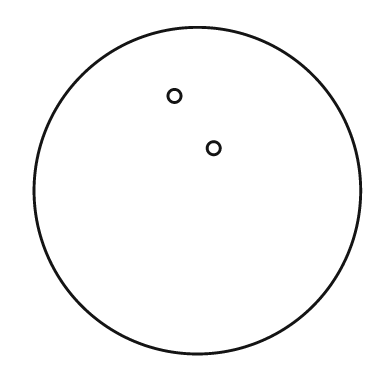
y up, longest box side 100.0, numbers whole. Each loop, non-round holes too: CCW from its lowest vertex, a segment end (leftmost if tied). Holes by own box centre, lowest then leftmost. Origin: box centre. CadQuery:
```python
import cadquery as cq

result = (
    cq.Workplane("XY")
    .moveTo(0.0, 0.0)
    .circle(50.0)
    .moveTo(5.0, 13.0)
    .circle(2.0)
    .moveTo(-7.0, 29.0)
    .circle(2.0)
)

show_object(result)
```